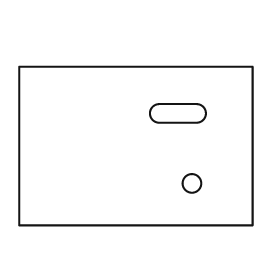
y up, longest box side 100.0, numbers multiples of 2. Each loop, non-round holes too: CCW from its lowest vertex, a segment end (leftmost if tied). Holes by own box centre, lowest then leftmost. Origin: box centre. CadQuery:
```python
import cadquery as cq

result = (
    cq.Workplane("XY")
    .moveTo(-50.0, -34.0)
    .lineTo(50.0, -34.0)
    .lineTo(50.0, 34.0)
    .lineTo(-50.0, 34.0)
    .close()
    .moveTo(24.0, -16.0)
    .circle(4.0)
    .moveTo(10.0, 10.0)
    .lineTo(26.0, 10.0)
    .threePointArc((30.0, 14.0), (26.0, 18.0))
    .lineTo(10.0, 18.0)
    .threePointArc((6.0, 14.0), (10.0, 10.0))
    .close()
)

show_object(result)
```